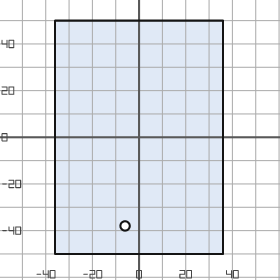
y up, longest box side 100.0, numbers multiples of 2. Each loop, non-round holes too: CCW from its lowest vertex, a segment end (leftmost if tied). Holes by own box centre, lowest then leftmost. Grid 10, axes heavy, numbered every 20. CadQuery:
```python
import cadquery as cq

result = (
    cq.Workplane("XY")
    .moveTo(-36.0, -50.0)
    .lineTo(36.0, -50.0)
    .lineTo(36.0, 50.0)
    .lineTo(-36.0, 50.0)
    .close()
    .moveTo(-6.0, -38.0)
    .circle(2.0)
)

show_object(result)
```